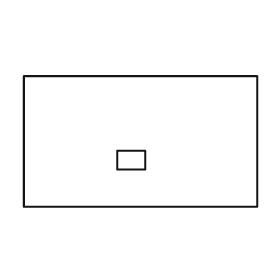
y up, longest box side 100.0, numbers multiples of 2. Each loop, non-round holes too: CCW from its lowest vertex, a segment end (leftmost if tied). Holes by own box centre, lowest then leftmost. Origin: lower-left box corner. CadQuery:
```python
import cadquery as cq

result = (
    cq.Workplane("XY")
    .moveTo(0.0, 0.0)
    .lineTo(100.0, 0.0)
    .lineTo(100.0, 56.0)
    .lineTo(0.0, 56.0)
    .close()
    .moveTo(40.0, 16.0)
    .lineTo(52.0, 16.0)
    .lineTo(52.0, 24.0)
    .lineTo(40.0, 24.0)
    .close()
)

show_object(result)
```